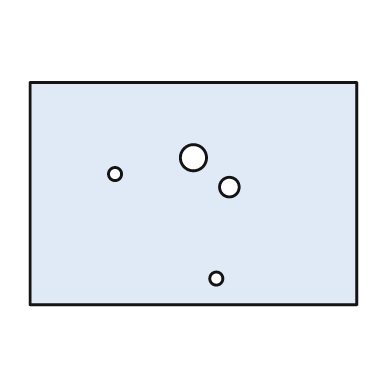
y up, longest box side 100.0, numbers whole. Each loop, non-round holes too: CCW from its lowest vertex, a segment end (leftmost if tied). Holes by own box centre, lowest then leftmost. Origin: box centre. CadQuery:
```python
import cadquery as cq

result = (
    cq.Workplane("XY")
    .moveTo(-50.0, -34.0)
    .lineTo(50.0, -34.0)
    .lineTo(50.0, 34.0)
    .lineTo(-50.0, 34.0)
    .close()
    .moveTo(7.0, -26.0)
    .circle(2.0)
    .moveTo(11.0, 2.0)
    .circle(3.0)
    .moveTo(-24.0, 6.0)
    .circle(2.0)
    .moveTo(0.0, 11.0)
    .circle(4.0)
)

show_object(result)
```